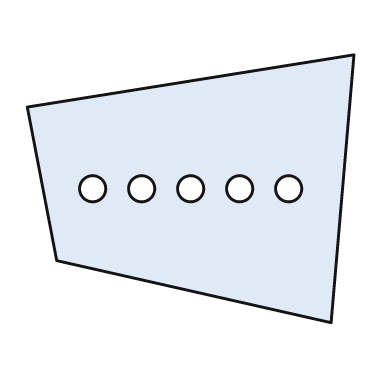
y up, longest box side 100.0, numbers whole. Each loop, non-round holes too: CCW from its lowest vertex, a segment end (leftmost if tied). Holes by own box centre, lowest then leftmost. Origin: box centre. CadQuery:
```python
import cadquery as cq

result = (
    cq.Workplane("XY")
    .moveTo(43.0, -41.0)
    .lineTo(50.0, 41.0)
    .lineTo(-50.0, 25.0)
    .lineTo(-41.0, -22.0)
    .close()
    .moveTo(-30.0, 0.0)
    .circle(4.0)
    .moveTo(-15.0, 0.0)
    .circle(4.0)
    .moveTo(0.0, 0.0)
    .circle(4.0)
    .moveTo(15.0, 0.0)
    .circle(4.0)
    .moveTo(30.0, 0.0)
    .circle(4.0)
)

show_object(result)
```